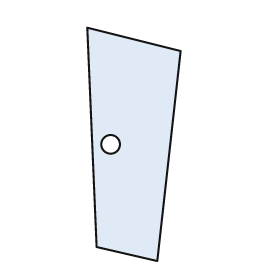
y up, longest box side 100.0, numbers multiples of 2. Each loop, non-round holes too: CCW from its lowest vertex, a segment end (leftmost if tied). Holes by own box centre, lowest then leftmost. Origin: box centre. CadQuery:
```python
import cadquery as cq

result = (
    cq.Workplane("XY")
    .moveTo(10.0, -50.0)
    .lineTo(20.0, 40.0)
    .lineTo(-20.0, 50.0)
    .lineTo(-16.0, -44.0)
    .close()
    .moveTo(-10.0, 0.0)
    .circle(4.0)
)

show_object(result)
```